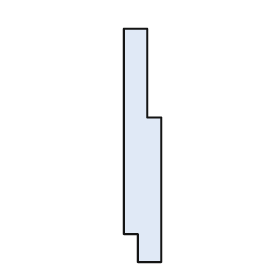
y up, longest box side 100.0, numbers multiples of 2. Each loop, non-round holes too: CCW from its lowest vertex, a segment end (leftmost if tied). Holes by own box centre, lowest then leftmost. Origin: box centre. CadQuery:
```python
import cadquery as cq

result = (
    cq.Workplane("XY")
    .moveTo(-2.0, -50.0)
    .lineTo(8.0, -50.0)
    .lineTo(8.0, 12.0)
    .lineTo(2.0, 12.0)
    .lineTo(2.0, 50.0)
    .lineTo(-8.0, 50.0)
    .lineTo(-8.0, -38.0)
    .lineTo(-2.0, -38.0)
    .close()
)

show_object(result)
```